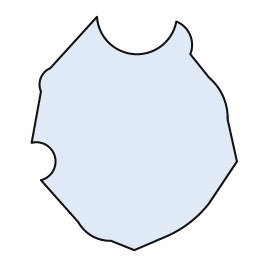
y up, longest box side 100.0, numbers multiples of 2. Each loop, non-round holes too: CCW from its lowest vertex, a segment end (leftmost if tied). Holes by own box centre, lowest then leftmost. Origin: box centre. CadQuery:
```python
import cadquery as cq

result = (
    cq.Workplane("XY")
    .moveTo(0.0, -50.0)
    .lineTo(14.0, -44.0)
    .threePointArc((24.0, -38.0), (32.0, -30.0))
    .lineTo(44.0, -12.0)
    .lineTo(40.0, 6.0)
    .threePointArc((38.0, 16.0), (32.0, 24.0))
    .lineTo(24.0, 34.0)
    .threePointArc((24.0, 42.0), (18.0, 48.0))
    .threePointArc((0.0, 34.0), (-16.0, 50.0))
    .lineTo(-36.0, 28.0)
    .threePointArc((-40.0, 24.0), (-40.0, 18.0))
    .lineTo(-44.0, -4.0)
    .threePointArc((-34.0, -10.0), (-40.0, -20.0))
    .lineTo(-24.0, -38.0)
    .threePointArc((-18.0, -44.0), (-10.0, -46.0))
    .close()
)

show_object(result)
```